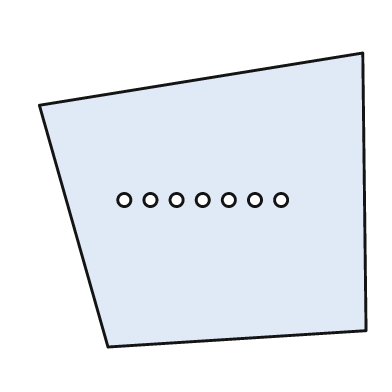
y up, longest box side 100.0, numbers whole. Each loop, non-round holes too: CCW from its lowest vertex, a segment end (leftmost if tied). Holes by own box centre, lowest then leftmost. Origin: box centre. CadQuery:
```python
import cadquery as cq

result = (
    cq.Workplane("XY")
    .moveTo(-29.0, -45.0)
    .lineTo(50.0, -40.0)
    .lineTo(49.0, 45.0)
    .lineTo(-50.0, 29.0)
    .close()
    .moveTo(-24.0, 0.0)
    .circle(2.0)
    .moveTo(-16.0, 0.0)
    .circle(2.0)
    .moveTo(-8.0, 0.0)
    .circle(2.0)
    .moveTo(0.0, 0.0)
    .circle(2.0)
    .moveTo(8.0, 0.0)
    .circle(2.0)
    .moveTo(16.0, 0.0)
    .circle(2.0)
    .moveTo(24.0, 0.0)
    .circle(2.0)
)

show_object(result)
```